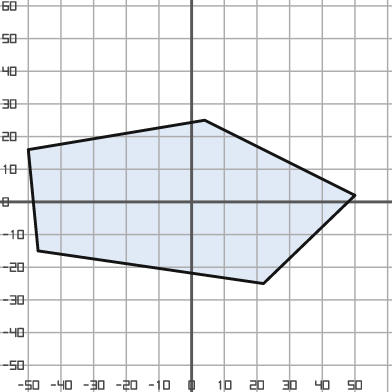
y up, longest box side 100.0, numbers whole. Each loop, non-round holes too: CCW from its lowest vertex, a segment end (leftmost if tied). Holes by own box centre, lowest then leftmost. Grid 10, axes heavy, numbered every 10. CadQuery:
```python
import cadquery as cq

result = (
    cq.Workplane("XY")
    .moveTo(22.0, -25.0)
    .lineTo(50.0, 2.0)
    .lineTo(4.0, 25.0)
    .lineTo(-50.0, 16.0)
    .lineTo(-47.0, -15.0)
    .close()
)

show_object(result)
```